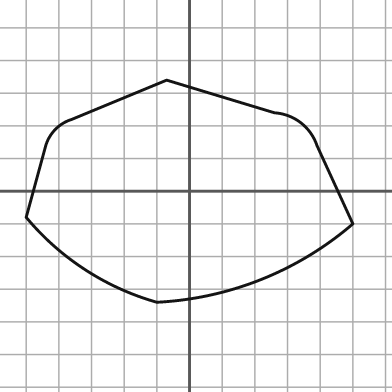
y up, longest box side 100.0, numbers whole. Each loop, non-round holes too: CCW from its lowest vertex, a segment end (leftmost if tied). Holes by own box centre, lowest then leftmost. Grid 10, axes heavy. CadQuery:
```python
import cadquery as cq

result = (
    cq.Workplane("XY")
    .moveTo(-10.0, -34.0)
    .threePointArc((22.0, -27.0), (50.0, -10.0))
    .lineTo(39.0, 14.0)
    .threePointArc((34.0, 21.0), (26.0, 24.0))
    .lineTo(-7.0, 34.0)
    .lineTo(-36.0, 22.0)
    .threePointArc((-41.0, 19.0), (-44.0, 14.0))
    .lineTo(-50.0, -8.0)
    .threePointArc((-32.0, -24.0), (-10.0, -34.0))
    .close()
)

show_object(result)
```